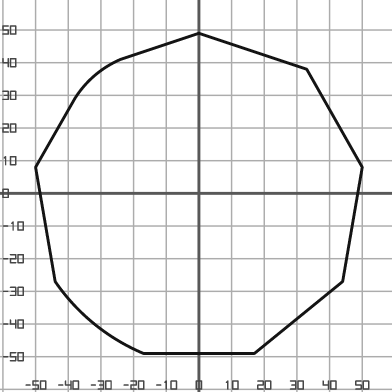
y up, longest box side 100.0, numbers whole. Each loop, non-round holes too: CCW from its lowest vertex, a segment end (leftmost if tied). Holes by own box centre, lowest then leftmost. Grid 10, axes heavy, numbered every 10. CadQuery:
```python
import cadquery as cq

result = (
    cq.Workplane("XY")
    .moveTo(-17.0, -49.0)
    .lineTo(17.0, -49.0)
    .lineTo(44.0, -27.0)
    .lineTo(50.0, 8.0)
    .lineTo(33.0, 38.0)
    .lineTo(0.0, 49.0)
    .lineTo(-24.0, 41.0)
    .threePointArc((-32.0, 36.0), (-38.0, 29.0))
    .lineTo(-50.0, 8.0)
    .lineTo(-44.0, -27.0)
    .threePointArc((-32.0, -40.0), (-17.0, -49.0))
    .close()
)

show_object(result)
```